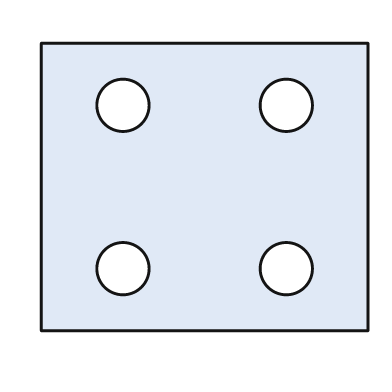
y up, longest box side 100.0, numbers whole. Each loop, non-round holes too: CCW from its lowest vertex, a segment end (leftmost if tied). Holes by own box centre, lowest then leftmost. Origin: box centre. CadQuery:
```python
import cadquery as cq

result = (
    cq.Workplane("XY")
    .moveTo(-50.0, -44.0)
    .lineTo(50.0, -44.0)
    .lineTo(50.0, 44.0)
    .lineTo(-50.0, 44.0)
    .close()
    .moveTo(-25.0, -25.0)
    .circle(8.0)
    .moveTo(25.0, -25.0)
    .circle(8.0)
    .moveTo(-25.0, 25.0)
    .circle(8.0)
    .moveTo(25.0, 25.0)
    .circle(8.0)
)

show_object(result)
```